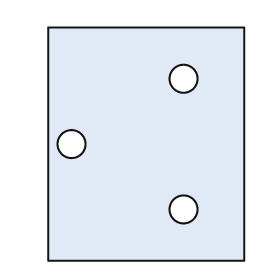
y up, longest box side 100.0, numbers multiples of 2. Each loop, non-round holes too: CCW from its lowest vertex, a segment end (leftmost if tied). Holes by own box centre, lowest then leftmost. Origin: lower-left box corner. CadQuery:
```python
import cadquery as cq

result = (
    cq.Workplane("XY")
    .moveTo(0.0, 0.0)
    .lineTo(84.0, 0.0)
    .lineTo(84.0, 100.0)
    .lineTo(0.0, 100.0)
    .close()
    .moveTo(58.0, 22.0)
    .circle(6.0)
    .moveTo(10.0, 50.0)
    .circle(6.0)
    .moveTo(58.0, 78.0)
    .circle(6.0)
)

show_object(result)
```